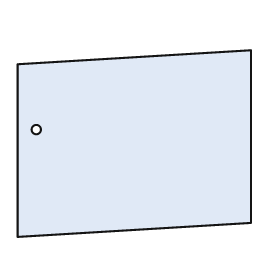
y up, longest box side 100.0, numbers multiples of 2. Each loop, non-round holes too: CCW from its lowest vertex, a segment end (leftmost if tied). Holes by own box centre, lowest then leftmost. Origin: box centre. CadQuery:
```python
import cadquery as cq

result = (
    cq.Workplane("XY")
    .moveTo(-50.0, -40.0)
    .lineTo(50.0, -34.0)
    .lineTo(50.0, 40.0)
    .lineTo(-50.0, 34.0)
    .close()
    .moveTo(-42.0, 6.0)
    .circle(2.0)
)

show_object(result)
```